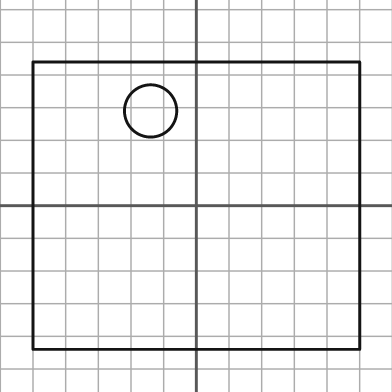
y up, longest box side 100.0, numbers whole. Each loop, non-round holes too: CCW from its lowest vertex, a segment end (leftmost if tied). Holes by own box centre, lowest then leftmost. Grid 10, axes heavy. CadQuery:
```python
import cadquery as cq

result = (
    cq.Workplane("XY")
    .moveTo(-50.0, -44.0)
    .lineTo(50.0, -44.0)
    .lineTo(50.0, 44.0)
    .lineTo(-50.0, 44.0)
    .close()
    .moveTo(-14.0, 29.0)
    .circle(8.0)
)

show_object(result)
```